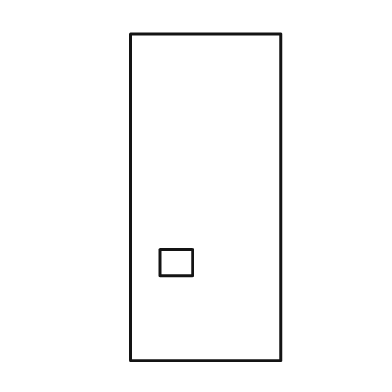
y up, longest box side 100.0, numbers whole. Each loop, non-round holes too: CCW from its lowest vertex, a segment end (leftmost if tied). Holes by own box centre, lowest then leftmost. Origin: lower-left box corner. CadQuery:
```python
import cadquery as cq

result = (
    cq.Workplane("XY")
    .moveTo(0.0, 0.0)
    .lineTo(46.0, 0.0)
    .lineTo(46.0, 100.0)
    .lineTo(0.0, 100.0)
    .close()
    .moveTo(9.0, 26.0)
    .lineTo(19.0, 26.0)
    .lineTo(19.0, 34.0)
    .lineTo(9.0, 34.0)
    .close()
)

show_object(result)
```